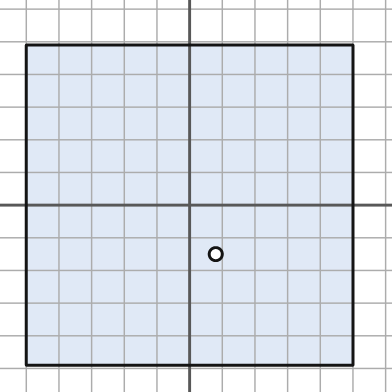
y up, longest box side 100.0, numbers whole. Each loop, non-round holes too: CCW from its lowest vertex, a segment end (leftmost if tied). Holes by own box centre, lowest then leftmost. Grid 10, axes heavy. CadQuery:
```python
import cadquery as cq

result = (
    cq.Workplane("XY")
    .moveTo(-50.0, -49.0)
    .lineTo(50.0, -49.0)
    .lineTo(50.0, 49.0)
    .lineTo(-50.0, 49.0)
    .close()
    .moveTo(8.0, -15.0)
    .circle(2.0)
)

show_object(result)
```